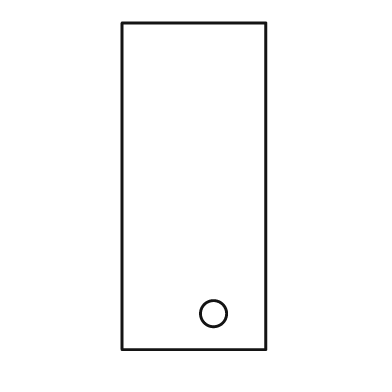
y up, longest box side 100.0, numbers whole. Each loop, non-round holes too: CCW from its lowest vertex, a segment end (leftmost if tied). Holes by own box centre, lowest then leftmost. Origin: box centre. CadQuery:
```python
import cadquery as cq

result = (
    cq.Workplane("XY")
    .moveTo(-22.0, -50.0)
    .lineTo(22.0, -50.0)
    .lineTo(22.0, 50.0)
    .lineTo(-22.0, 50.0)
    .close()
    .moveTo(6.0, -39.0)
    .circle(4.0)
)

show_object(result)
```